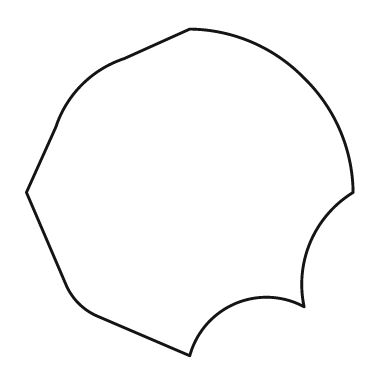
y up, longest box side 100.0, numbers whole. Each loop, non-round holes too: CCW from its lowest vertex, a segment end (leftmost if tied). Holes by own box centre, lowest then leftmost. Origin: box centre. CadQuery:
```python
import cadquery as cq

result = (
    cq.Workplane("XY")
    .moveTo(0.0, -50.0)
    .threePointArc((14.0, -34.0), (35.0, -35.0))
    .threePointArc((37.0, -15.0), (50.0, 0.0))
    .threePointArc((46.0, 19.0), (35.0, 35.0))
    .threePointArc((19.0, 46.0), (0.0, 50.0))
    .lineTo(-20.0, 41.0)
    .threePointArc((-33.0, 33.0), (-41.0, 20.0))
    .lineTo(-50.0, 0.0)
    .lineTo(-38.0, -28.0)
    .threePointArc((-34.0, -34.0), (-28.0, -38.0))
    .close()
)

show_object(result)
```